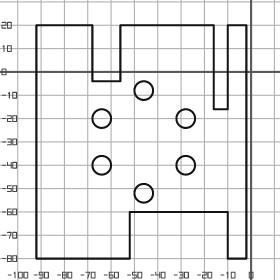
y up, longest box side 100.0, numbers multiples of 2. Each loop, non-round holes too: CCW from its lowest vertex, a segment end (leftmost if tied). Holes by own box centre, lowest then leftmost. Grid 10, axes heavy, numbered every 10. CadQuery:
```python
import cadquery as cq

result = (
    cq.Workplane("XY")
    .moveTo(-92.0, -80.0)
    .lineTo(-52.0, -80.0)
    .lineTo(-52.0, -60.0)
    .lineTo(-10.0, -60.0)
    .lineTo(-10.0, -80.0)
    .lineTo(-2.0, -80.0)
    .lineTo(-2.0, 20.0)
    .lineTo(-10.0, 20.0)
    .lineTo(-10.0, -16.0)
    .lineTo(-16.0, -16.0)
    .lineTo(-16.0, 20.0)
    .lineTo(-56.0, 20.0)
    .lineTo(-56.0, -4.0)
    .lineTo(-68.0, -4.0)
    .lineTo(-68.0, 20.0)
    .lineTo(-92.0, 20.0)
    .close()
    .moveTo(-46.0, -52.0)
    .circle(4.0)
    .moveTo(-64.0, -40.0)
    .circle(4.0)
    .moveTo(-28.0, -40.0)
    .circle(4.0)
    .moveTo(-64.0, -20.0)
    .circle(4.0)
    .moveTo(-28.0, -20.0)
    .circle(4.0)
    .moveTo(-46.0, -8.0)
    .circle(4.0)
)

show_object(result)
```